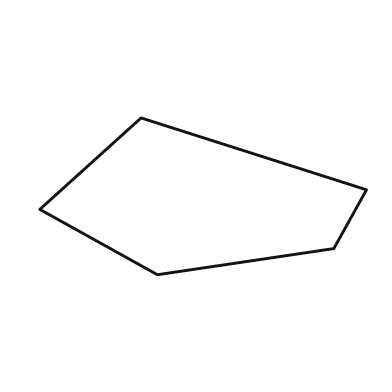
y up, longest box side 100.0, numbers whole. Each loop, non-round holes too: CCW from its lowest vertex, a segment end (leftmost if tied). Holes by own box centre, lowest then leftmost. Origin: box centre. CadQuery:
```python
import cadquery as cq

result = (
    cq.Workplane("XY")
    .moveTo(-14.0, -24.0)
    .lineTo(40.0, -16.0)
    .lineTo(50.0, 2.0)
    .lineTo(-19.0, 24.0)
    .lineTo(-50.0, -4.0)
    .close()
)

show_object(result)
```